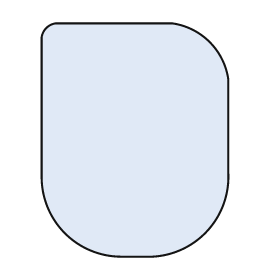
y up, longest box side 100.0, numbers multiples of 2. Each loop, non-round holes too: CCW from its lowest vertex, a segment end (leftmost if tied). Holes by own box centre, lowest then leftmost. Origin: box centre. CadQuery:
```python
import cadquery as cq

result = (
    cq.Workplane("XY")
    .moveTo(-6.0, -50.0)
    .lineTo(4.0, -50.0)
    .threePointArc((30.0, -40.0), (40.0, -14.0))
    .lineTo(40.0, 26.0)
    .threePointArc((32.0, 42.0), (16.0, 50.0))
    .lineTo(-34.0, 50.0)
    .threePointArc((-38.0, 48.0), (-40.0, 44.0))
    .lineTo(-40.0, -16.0)
    .threePointArc((-30.0, -40.0), (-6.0, -50.0))
    .close()
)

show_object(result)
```